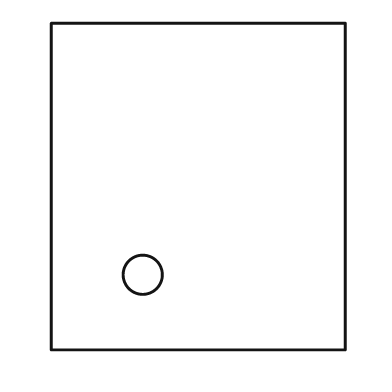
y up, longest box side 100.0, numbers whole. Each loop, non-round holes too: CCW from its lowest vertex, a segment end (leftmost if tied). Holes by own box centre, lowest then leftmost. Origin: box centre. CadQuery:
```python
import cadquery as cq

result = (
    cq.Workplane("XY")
    .moveTo(-45.0, -50.0)
    .lineTo(45.0, -50.0)
    .lineTo(45.0, 50.0)
    .lineTo(-45.0, 50.0)
    .close()
    .moveTo(-17.0, -27.0)
    .circle(6.0)
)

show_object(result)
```